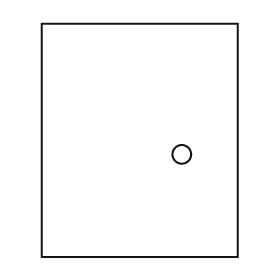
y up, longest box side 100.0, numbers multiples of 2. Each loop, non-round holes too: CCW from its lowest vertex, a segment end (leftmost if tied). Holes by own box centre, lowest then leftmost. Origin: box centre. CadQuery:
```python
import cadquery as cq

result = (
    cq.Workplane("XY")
    .moveTo(-42.0, -50.0)
    .lineTo(42.0, -50.0)
    .lineTo(42.0, 50.0)
    .lineTo(-42.0, 50.0)
    .close()
    .moveTo(18.0, -6.0)
    .circle(4.0)
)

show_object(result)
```